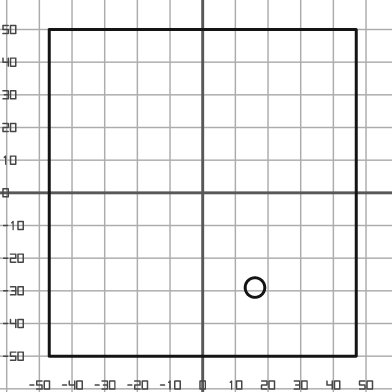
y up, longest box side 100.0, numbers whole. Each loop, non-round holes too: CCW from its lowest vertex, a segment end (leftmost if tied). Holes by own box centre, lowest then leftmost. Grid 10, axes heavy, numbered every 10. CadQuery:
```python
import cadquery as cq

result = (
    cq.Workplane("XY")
    .moveTo(-47.0, -50.0)
    .lineTo(47.0, -50.0)
    .lineTo(47.0, 50.0)
    .lineTo(-47.0, 50.0)
    .close()
    .moveTo(16.0, -29.0)
    .circle(3.0)
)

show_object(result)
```